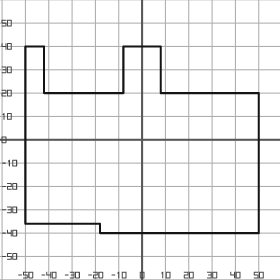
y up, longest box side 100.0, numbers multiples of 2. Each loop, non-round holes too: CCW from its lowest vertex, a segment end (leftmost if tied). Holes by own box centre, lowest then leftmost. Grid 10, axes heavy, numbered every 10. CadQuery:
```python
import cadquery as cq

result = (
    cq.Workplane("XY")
    .moveTo(-18.0, -40.0)
    .lineTo(50.0, -40.0)
    .lineTo(50.0, 20.0)
    .lineTo(8.0, 20.0)
    .lineTo(8.0, 40.0)
    .lineTo(-8.0, 40.0)
    .lineTo(-8.0, 20.0)
    .lineTo(-42.0, 20.0)
    .lineTo(-42.0, 40.0)
    .lineTo(-50.0, 40.0)
    .lineTo(-50.0, -36.0)
    .lineTo(-18.0, -36.0)
    .close()
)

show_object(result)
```